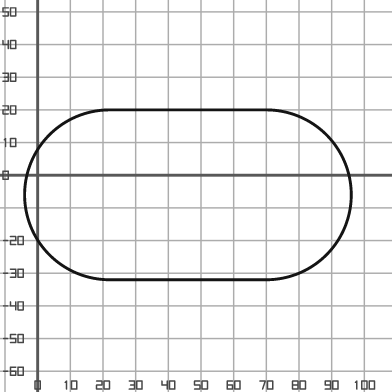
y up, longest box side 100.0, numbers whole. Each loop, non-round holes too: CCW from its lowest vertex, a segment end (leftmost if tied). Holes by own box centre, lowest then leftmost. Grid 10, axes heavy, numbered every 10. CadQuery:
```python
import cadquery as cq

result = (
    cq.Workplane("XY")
    .moveTo(22.0, -32.0)
    .lineTo(70.0, -32.0)
    .threePointArc((96.0, -6.0), (70.0, 20.0))
    .lineTo(22.0, 20.0)
    .threePointArc((-4.0, -6.0), (22.0, -32.0))
    .close()
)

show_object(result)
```